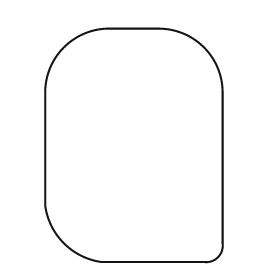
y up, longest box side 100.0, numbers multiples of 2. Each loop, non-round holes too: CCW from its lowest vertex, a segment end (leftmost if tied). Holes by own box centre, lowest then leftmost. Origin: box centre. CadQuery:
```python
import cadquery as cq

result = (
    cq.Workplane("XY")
    .moveTo(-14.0, -50.0)
    .lineTo(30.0, -50.0)
    .threePointArc((36.0, -48.0), (38.0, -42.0))
    .lineTo(38.0, 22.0)
    .threePointArc((30.0, 42.0), (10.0, 50.0))
    .lineTo(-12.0, 50.0)
    .threePointArc((-30.0, 42.0), (-38.0, 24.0))
    .lineTo(-38.0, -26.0)
    .threePointArc((-30.0, -42.0), (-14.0, -50.0))
    .close()
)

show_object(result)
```